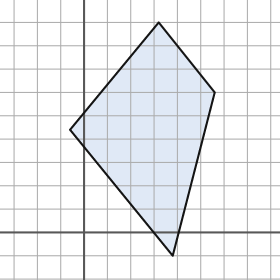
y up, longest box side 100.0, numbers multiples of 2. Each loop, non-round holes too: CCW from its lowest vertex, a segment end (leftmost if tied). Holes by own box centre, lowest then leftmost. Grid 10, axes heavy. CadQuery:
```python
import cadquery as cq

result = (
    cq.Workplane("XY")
    .moveTo(38.0, -10.0)
    .lineTo(56.0, 60.0)
    .lineTo(32.0, 90.0)
    .lineTo(-6.0, 44.0)
    .close()
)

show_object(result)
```